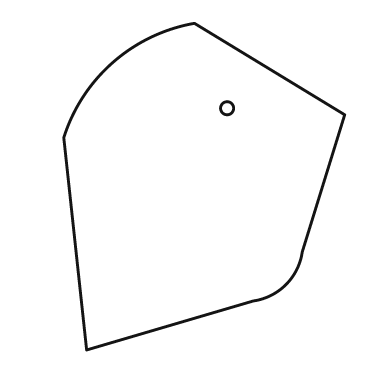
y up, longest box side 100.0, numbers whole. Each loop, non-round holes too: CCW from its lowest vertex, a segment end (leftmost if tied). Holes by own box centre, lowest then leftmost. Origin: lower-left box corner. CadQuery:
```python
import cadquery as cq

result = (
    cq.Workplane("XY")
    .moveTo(7.0, 0.0)
    .lineTo(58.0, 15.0)
    .threePointArc((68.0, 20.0), (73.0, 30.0))
    .lineTo(86.0, 72.0)
    .lineTo(40.0, 100.0)
    .threePointArc((15.0, 88.0), (0.0, 65.0))
    .close()
    .moveTo(50.0, 74.0)
    .circle(2.0)
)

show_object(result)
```